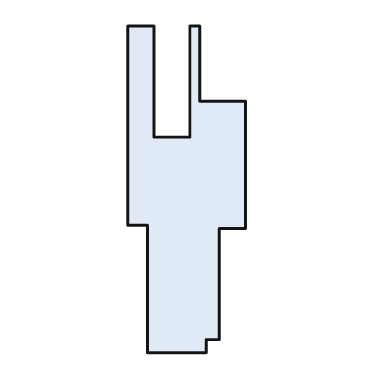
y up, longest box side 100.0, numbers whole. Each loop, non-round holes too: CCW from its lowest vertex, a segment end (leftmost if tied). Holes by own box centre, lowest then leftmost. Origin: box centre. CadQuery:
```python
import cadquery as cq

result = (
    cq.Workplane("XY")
    .moveTo(-12.0, -50.0)
    .lineTo(6.0, -50.0)
    .lineTo(6.0, -46.0)
    .lineTo(10.0, -46.0)
    .lineTo(10.0, -12.0)
    .lineTo(18.0, -12.0)
    .lineTo(18.0, 27.0)
    .lineTo(4.0, 27.0)
    .lineTo(4.0, 50.0)
    .lineTo(1.0, 50.0)
    .lineTo(1.0, 16.0)
    .lineTo(-10.0, 16.0)
    .lineTo(-10.0, 50.0)
    .lineTo(-18.0, 50.0)
    .lineTo(-18.0, -11.0)
    .lineTo(-12.0, -11.0)
    .close()
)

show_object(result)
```